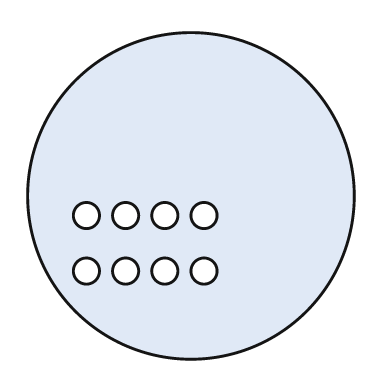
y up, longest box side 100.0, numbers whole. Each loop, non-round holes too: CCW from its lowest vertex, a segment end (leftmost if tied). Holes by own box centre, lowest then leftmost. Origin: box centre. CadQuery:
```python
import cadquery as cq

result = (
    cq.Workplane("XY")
    .moveTo(0.0, 0.0)
    .circle(50.0)
    .moveTo(-32.0, -23.0)
    .circle(4.0)
    .moveTo(-20.0, -23.0)
    .circle(4.0)
    .moveTo(-8.0, -23.0)
    .circle(4.0)
    .moveTo(4.0, -23.0)
    .circle(4.0)
    .moveTo(-32.0, -6.0)
    .circle(4.0)
    .moveTo(-20.0, -6.0)
    .circle(4.0)
    .moveTo(-8.0, -6.0)
    .circle(4.0)
    .moveTo(4.0, -6.0)
    .circle(4.0)
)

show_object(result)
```